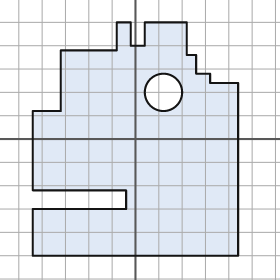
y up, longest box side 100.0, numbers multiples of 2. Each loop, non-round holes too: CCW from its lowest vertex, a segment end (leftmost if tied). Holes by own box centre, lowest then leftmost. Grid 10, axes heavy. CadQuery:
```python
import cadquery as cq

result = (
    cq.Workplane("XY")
    .moveTo(-44.0, -50.0)
    .lineTo(44.0, -50.0)
    .lineTo(44.0, 24.0)
    .lineTo(32.0, 24.0)
    .lineTo(32.0, 28.0)
    .lineTo(26.0, 28.0)
    .lineTo(26.0, 36.0)
    .lineTo(22.0, 36.0)
    .lineTo(22.0, 50.0)
    .lineTo(4.0, 50.0)
    .lineTo(4.0, 40.0)
    .lineTo(-2.0, 40.0)
    .lineTo(-2.0, 50.0)
    .lineTo(-8.0, 50.0)
    .lineTo(-8.0, 38.0)
    .lineTo(-32.0, 38.0)
    .lineTo(-32.0, 12.0)
    .lineTo(-44.0, 12.0)
    .lineTo(-44.0, -22.0)
    .lineTo(-4.0, -22.0)
    .lineTo(-4.0, -30.0)
    .lineTo(-44.0, -30.0)
    .close()
    .moveTo(12.0, 20.0)
    .circle(8.0)
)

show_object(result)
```